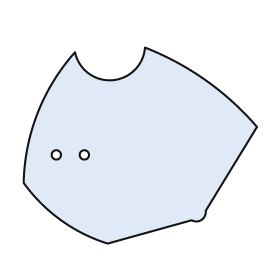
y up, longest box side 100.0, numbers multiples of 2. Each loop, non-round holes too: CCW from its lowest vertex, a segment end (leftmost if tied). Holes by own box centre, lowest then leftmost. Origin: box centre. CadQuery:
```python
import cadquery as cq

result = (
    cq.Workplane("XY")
    .moveTo(-14.0, -42.0)
    .lineTo(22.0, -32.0)
    .threePointArc((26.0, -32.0), (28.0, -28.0))
    .lineTo(50.0, 8.0)
    .threePointArc((28.0, 28.0), (2.0, 42.0))
    .threePointArc((-12.0, 28.0), (-28.0, 40.0))
    .threePointArc((-44.0, 14.0), (-50.0, -16.0))
    .threePointArc((-34.0, -32.0), (-14.0, -42.0))
    .close()
    .moveTo(-36.0, -4.0)
    .circle(2.0)
    .moveTo(-24.0, -4.0)
    .circle(2.0)
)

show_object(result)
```